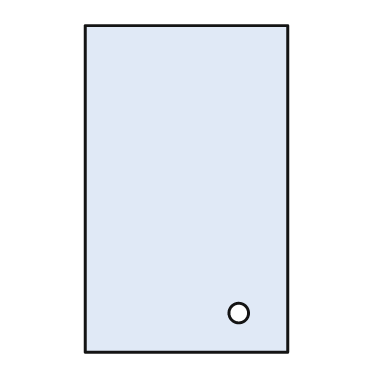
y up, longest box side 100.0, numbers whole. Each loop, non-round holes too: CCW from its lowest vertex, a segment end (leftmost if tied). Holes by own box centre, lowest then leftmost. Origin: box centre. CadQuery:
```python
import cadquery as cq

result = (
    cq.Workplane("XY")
    .moveTo(-31.0, -50.0)
    .lineTo(31.0, -50.0)
    .lineTo(31.0, 50.0)
    .lineTo(-31.0, 50.0)
    .close()
    .moveTo(16.0, -38.0)
    .circle(3.0)
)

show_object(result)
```